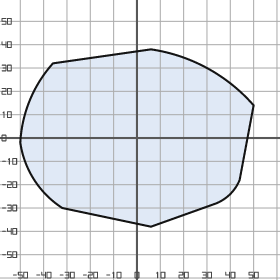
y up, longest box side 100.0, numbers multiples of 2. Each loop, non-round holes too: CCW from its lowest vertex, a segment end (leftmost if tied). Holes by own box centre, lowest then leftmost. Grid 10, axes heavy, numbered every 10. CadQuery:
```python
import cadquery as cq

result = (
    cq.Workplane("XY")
    .moveTo(6.0, -38.0)
    .lineTo(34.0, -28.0)
    .threePointArc((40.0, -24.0), (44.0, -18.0))
    .lineTo(50.0, 14.0)
    .threePointArc((30.0, 30.0), (6.0, 38.0))
    .lineTo(-36.0, 32.0)
    .threePointArc((-46.0, 16.0), (-50.0, -2.0))
    .threePointArc((-44.0, -18.0), (-32.0, -30.0))
    .close()
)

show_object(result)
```